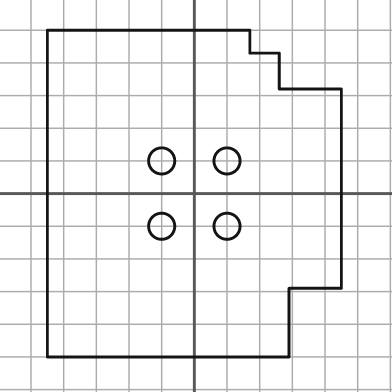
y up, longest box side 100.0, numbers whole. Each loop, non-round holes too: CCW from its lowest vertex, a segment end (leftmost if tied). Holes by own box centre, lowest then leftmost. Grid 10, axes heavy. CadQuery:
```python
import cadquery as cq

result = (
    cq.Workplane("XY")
    .moveTo(-45.0, -50.0)
    .lineTo(29.0, -50.0)
    .lineTo(29.0, -29.0)
    .lineTo(45.0, -29.0)
    .lineTo(45.0, 32.0)
    .lineTo(26.0, 32.0)
    .lineTo(26.0, 43.0)
    .lineTo(17.0, 43.0)
    .lineTo(17.0, 50.0)
    .lineTo(-45.0, 50.0)
    .close()
    .moveTo(-10.0, -10.0)
    .circle(4.0)
    .moveTo(10.0, -10.0)
    .circle(4.0)
    .moveTo(-10.0, 10.0)
    .circle(4.0)
    .moveTo(10.0, 10.0)
    .circle(4.0)
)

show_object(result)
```